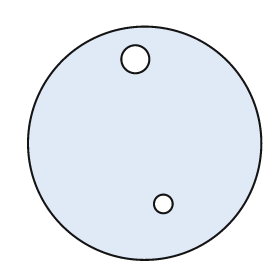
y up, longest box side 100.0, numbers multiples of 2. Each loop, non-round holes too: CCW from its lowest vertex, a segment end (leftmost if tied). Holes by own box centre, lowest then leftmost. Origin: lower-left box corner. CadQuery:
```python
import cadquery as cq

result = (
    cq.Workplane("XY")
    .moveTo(50.0, 50.0)
    .circle(50.0)
    .moveTo(58.0, 24.0)
    .circle(4.0)
    .moveTo(46.0, 86.0)
    .circle(6.0)
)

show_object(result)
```